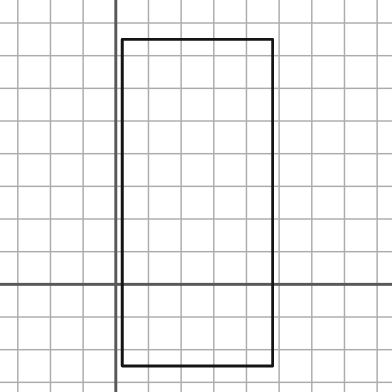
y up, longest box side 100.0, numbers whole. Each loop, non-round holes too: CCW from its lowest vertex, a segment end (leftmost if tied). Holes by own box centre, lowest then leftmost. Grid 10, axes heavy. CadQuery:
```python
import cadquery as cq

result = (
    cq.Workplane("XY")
    .moveTo(2.0, -25.0)
    .lineTo(48.0, -25.0)
    .lineTo(48.0, 75.0)
    .lineTo(2.0, 75.0)
    .close()
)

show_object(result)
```